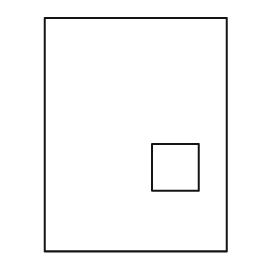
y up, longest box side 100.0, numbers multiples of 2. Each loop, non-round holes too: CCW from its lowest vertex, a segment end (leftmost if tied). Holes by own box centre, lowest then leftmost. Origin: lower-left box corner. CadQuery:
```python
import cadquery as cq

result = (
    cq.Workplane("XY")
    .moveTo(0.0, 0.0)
    .lineTo(78.0, 0.0)
    .lineTo(78.0, 100.0)
    .lineTo(0.0, 100.0)
    .close()
    .moveTo(46.0, 26.0)
    .lineTo(66.0, 26.0)
    .lineTo(66.0, 46.0)
    .lineTo(46.0, 46.0)
    .close()
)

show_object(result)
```